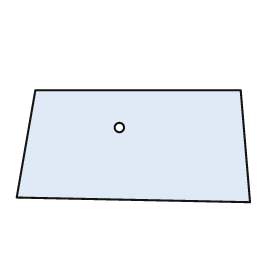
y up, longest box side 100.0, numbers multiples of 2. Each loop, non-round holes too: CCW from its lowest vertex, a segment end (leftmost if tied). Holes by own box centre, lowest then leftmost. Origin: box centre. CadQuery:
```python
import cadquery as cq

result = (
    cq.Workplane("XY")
    .moveTo(50.0, -24.0)
    .lineTo(46.0, 24.0)
    .lineTo(-42.0, 24.0)
    .lineTo(-50.0, -22.0)
    .close()
    .moveTo(-6.0, 8.0)
    .circle(2.0)
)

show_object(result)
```